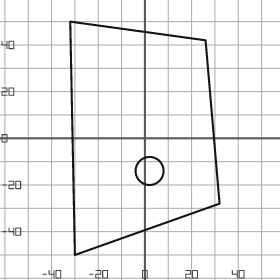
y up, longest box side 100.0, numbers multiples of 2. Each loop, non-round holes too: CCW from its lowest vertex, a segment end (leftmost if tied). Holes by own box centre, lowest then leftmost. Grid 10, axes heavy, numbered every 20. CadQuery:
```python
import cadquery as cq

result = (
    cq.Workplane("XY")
    .moveTo(-30.0, -50.0)
    .lineTo(32.0, -28.0)
    .lineTo(26.0, 42.0)
    .lineTo(-32.0, 50.0)
    .close()
    .moveTo(2.0, -14.0)
    .circle(6.0)
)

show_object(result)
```